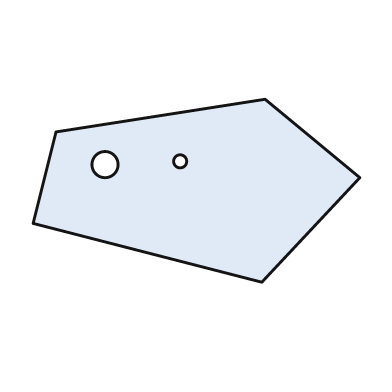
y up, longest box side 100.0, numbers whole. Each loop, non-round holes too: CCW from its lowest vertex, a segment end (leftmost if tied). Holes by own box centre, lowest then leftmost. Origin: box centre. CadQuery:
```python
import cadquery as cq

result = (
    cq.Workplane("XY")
    .moveTo(20.0, -28.0)
    .lineTo(50.0, 4.0)
    .lineTo(21.0, 28.0)
    .lineTo(-43.0, 18.0)
    .lineTo(-50.0, -10.0)
    .close()
    .moveTo(-28.0, 8.0)
    .circle(4.0)
    .moveTo(-5.0, 9.0)
    .circle(2.0)
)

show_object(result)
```